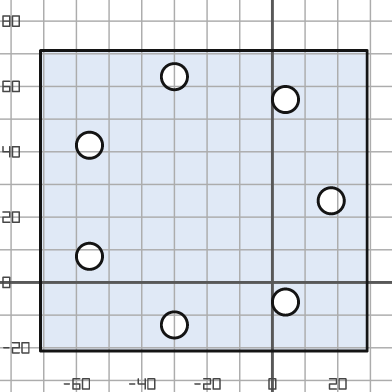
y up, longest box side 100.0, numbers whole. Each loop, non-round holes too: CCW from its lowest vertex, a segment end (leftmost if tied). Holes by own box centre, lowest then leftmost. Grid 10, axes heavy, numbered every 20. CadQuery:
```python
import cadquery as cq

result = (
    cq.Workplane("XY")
    .moveTo(-71.0, -21.0)
    .lineTo(29.0, -21.0)
    .lineTo(29.0, 71.0)
    .lineTo(-71.0, 71.0)
    .close()
    .moveTo(-30.0, -13.0)
    .circle(4.0)
    .moveTo(4.0, -6.0)
    .circle(4.0)
    .moveTo(-56.0, 8.0)
    .circle(4.0)
    .moveTo(18.0, 25.0)
    .circle(4.0)
    .moveTo(-56.0, 42.0)
    .circle(4.0)
    .moveTo(4.0, 56.0)
    .circle(4.0)
    .moveTo(-30.0, 63.0)
    .circle(4.0)
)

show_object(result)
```